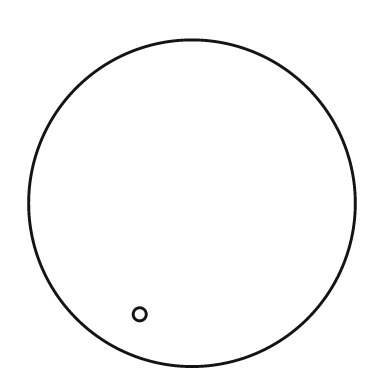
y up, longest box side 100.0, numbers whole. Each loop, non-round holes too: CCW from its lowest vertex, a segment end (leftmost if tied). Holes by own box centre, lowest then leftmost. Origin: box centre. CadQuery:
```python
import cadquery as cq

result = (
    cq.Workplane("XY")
    .moveTo(0.0, 0.0)
    .circle(50.0)
    .moveTo(-16.0, -34.0)
    .circle(2.0)
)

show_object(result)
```